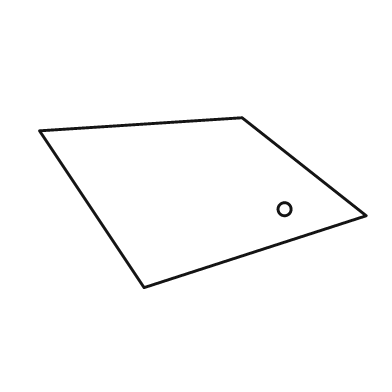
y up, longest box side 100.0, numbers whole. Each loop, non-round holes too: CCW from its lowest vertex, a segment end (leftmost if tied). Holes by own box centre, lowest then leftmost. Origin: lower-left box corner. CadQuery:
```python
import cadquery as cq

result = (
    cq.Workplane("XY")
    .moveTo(32.0, 0.0)
    .lineTo(100.0, 22.0)
    .lineTo(62.0, 52.0)
    .lineTo(0.0, 48.0)
    .close()
    .moveTo(75.0, 24.0)
    .circle(2.0)
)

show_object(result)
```